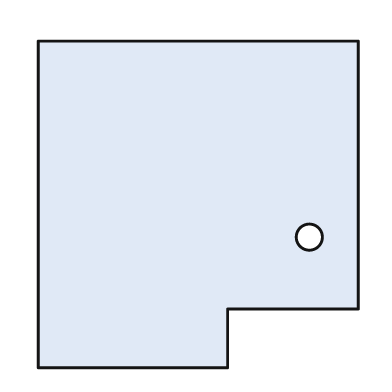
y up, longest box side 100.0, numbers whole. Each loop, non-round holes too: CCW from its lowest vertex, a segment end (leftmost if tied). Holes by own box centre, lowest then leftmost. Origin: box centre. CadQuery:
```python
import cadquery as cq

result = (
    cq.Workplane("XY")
    .moveTo(-49.0, -50.0)
    .lineTo(9.0, -50.0)
    .lineTo(9.0, -32.0)
    .lineTo(49.0, -32.0)
    .lineTo(49.0, 50.0)
    .lineTo(-49.0, 50.0)
    .close()
    .moveTo(34.0, -10.0)
    .circle(4.0)
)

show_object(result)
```